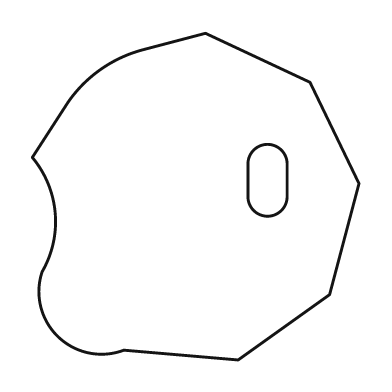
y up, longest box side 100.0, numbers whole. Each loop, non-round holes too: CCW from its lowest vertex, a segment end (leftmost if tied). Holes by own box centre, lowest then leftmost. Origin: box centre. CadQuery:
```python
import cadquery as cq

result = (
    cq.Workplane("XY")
    .moveTo(13.0, -50.0)
    .lineTo(41.0, -30.0)
    .lineTo(50.0, 4.0)
    .lineTo(35.0, 35.0)
    .lineTo(3.0, 50.0)
    .lineTo(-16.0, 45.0)
    .threePointArc((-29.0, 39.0), (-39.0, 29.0))
    .lineTo(-50.0, 12.0)
    .threePointArc((-43.0, -5.0), (-47.0, -23.0))
    .threePointArc((-42.0, -43.0), (-22.0, -47.0))
    .close()
    .moveTo(16.0, 0.0)
    .threePointArc((22.0, -6.0), (28.0, 0.0))
    .lineTo(28.0, 10.0)
    .threePointArc((22.0, 16.0), (16.0, 10.0))
    .close()
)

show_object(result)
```